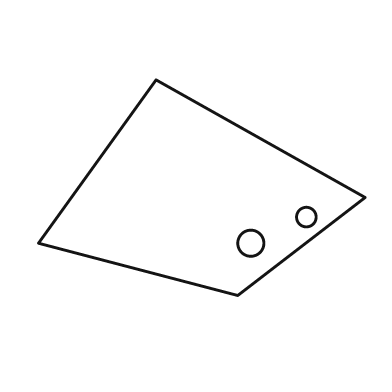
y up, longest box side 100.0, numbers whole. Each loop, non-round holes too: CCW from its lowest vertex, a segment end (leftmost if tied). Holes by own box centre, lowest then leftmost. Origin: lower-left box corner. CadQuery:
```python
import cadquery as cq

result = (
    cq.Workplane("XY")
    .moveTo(61.0, 0.0)
    .lineTo(100.0, 30.0)
    .lineTo(36.0, 66.0)
    .lineTo(0.0, 16.0)
    .close()
    .moveTo(65.0, 16.0)
    .circle(4.0)
    .moveTo(82.0, 24.0)
    .circle(3.0)
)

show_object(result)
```